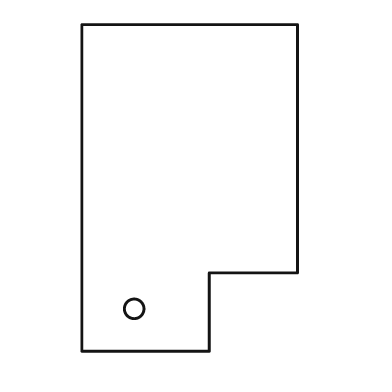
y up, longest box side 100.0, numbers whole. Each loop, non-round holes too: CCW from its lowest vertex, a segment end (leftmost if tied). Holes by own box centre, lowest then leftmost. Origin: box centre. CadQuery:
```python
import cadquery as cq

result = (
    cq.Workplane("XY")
    .moveTo(-33.0, -50.0)
    .lineTo(6.0, -50.0)
    .lineTo(6.0, -26.0)
    .lineTo(33.0, -26.0)
    .lineTo(33.0, 50.0)
    .lineTo(-33.0, 50.0)
    .close()
    .moveTo(-17.0, -37.0)
    .circle(3.0)
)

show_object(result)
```